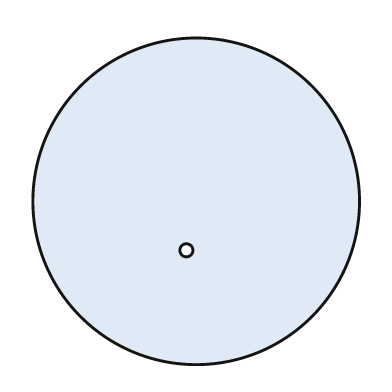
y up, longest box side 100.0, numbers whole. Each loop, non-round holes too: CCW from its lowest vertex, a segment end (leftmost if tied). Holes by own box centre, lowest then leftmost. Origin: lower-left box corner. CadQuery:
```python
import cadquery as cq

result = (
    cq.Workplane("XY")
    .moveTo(50.0, 50.0)
    .circle(50.0)
    .moveTo(47.0, 35.0)
    .circle(2.0)
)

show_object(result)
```